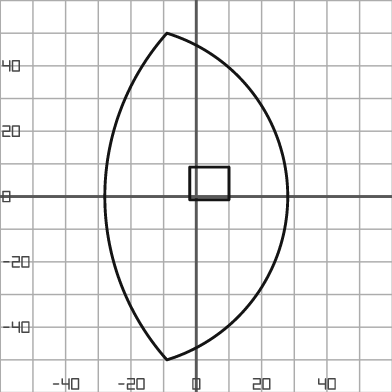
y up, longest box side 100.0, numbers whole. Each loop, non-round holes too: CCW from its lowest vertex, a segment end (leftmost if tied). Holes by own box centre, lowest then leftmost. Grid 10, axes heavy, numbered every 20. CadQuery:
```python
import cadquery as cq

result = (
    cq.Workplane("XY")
    .moveTo(-9.0, -50.0)
    .threePointArc((28.0, 0.0), (-9.0, 50.0))
    .threePointArc((-28.0, 0.0), (-9.0, -50.0))
    .close()
    .moveTo(-2.0, -1.0)
    .lineTo(10.0, -1.0)
    .lineTo(10.0, 9.0)
    .lineTo(-2.0, 9.0)
    .close()
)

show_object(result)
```